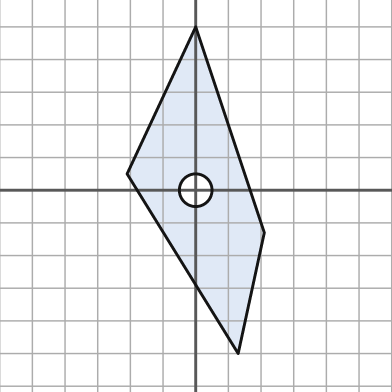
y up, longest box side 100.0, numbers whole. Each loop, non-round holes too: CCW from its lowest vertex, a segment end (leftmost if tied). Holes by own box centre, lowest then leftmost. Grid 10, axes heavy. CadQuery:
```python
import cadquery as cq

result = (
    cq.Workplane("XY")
    .moveTo(13.0, -50.0)
    .lineTo(21.0, -13.0)
    .lineTo(0.0, 50.0)
    .lineTo(-21.0, 5.0)
    .close()
    .moveTo(0.0, 0.0)
    .circle(5.0)
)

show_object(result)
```